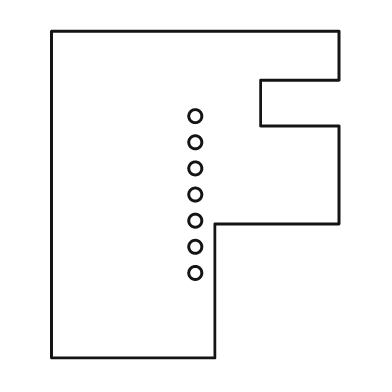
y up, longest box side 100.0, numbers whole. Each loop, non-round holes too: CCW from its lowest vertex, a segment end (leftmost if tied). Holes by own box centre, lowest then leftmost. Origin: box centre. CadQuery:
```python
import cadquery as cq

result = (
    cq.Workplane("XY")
    .moveTo(-44.0, -50.0)
    .lineTo(6.0, -50.0)
    .lineTo(6.0, -9.0)
    .lineTo(44.0, -9.0)
    .lineTo(44.0, 21.0)
    .lineTo(20.0, 21.0)
    .lineTo(20.0, 35.0)
    .lineTo(44.0, 35.0)
    .lineTo(44.0, 50.0)
    .lineTo(-44.0, 50.0)
    .close()
    .moveTo(0.0, -24.0)
    .circle(2.0)
    .moveTo(0.0, -16.0)
    .circle(2.0)
    .moveTo(0.0, -8.0)
    .circle(2.0)
    .moveTo(0.0, 0.0)
    .circle(2.0)
    .moveTo(0.0, 8.0)
    .circle(2.0)
    .moveTo(0.0, 16.0)
    .circle(2.0)
    .moveTo(0.0, 24.0)
    .circle(2.0)
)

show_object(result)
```